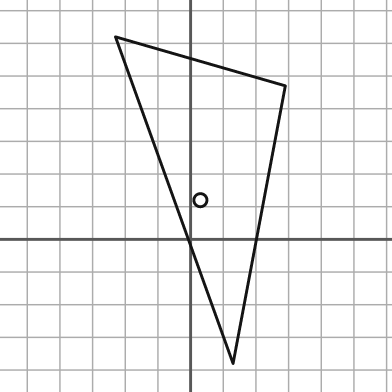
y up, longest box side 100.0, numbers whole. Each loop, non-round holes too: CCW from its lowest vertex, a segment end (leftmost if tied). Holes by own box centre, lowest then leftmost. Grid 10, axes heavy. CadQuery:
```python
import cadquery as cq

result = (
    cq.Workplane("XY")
    .moveTo(13.0, -38.0)
    .lineTo(29.0, 47.0)
    .lineTo(-23.0, 62.0)
    .close()
    .moveTo(3.0, 12.0)
    .circle(2.0)
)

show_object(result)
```